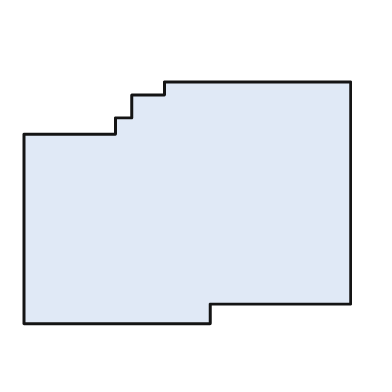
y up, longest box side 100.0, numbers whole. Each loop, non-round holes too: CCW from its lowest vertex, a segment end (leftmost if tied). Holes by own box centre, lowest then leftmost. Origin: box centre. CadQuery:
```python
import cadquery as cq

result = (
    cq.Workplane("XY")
    .moveTo(-50.0, -37.0)
    .lineTo(7.0, -37.0)
    .lineTo(7.0, -31.0)
    .lineTo(50.0, -31.0)
    .lineTo(50.0, 37.0)
    .lineTo(-7.0, 37.0)
    .lineTo(-7.0, 33.0)
    .lineTo(-17.0, 33.0)
    .lineTo(-17.0, 26.0)
    .lineTo(-22.0, 26.0)
    .lineTo(-22.0, 21.0)
    .lineTo(-50.0, 21.0)
    .close()
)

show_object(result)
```